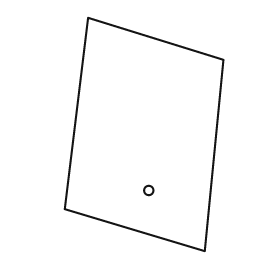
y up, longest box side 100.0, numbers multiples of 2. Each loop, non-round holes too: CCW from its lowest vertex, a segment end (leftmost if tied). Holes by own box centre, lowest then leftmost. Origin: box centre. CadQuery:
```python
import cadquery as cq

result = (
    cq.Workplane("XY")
    .moveTo(26.0, -50.0)
    .lineTo(34.0, 32.0)
    .lineTo(-24.0, 50.0)
    .lineTo(-34.0, -32.0)
    .close()
    .moveTo(2.0, -24.0)
    .circle(2.0)
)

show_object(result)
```